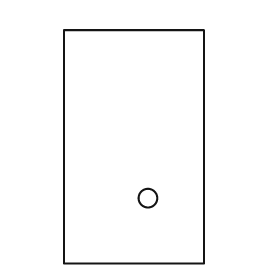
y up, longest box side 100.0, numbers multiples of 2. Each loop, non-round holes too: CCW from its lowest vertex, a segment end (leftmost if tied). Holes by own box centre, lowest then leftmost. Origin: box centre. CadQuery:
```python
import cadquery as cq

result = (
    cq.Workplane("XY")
    .moveTo(-30.0, -50.0)
    .lineTo(30.0, -50.0)
    .lineTo(30.0, 50.0)
    .lineTo(-30.0, 50.0)
    .close()
    .moveTo(6.0, -22.0)
    .circle(4.0)
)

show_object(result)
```